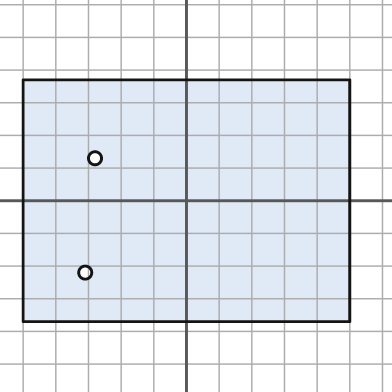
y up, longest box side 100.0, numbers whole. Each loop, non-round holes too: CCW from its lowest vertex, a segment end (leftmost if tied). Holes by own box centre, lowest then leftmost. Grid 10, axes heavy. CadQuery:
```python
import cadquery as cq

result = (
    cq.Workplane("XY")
    .moveTo(-50.0, -37.0)
    .lineTo(50.0, -37.0)
    .lineTo(50.0, 37.0)
    .lineTo(-50.0, 37.0)
    .close()
    .moveTo(-31.0, -22.0)
    .circle(2.0)
    .moveTo(-28.0, 13.0)
    .circle(2.0)
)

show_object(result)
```